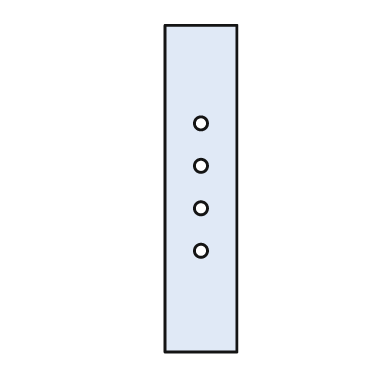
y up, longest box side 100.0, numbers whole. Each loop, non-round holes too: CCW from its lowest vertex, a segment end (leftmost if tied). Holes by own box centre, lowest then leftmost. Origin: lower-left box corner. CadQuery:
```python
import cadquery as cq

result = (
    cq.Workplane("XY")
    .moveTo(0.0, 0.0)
    .lineTo(22.0, 0.0)
    .lineTo(22.0, 100.0)
    .lineTo(0.0, 100.0)
    .close()
    .moveTo(11.0, 31.0)
    .circle(2.0)
    .moveTo(11.0, 44.0)
    .circle(2.0)
    .moveTo(11.0, 57.0)
    .circle(2.0)
    .moveTo(11.0, 70.0)
    .circle(2.0)
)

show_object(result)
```